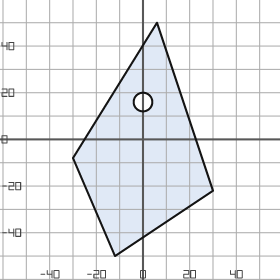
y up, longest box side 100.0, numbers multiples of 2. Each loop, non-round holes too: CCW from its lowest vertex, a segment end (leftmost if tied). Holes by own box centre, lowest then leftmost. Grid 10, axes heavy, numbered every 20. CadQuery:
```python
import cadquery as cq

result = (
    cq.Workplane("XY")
    .moveTo(-12.0, -50.0)
    .lineTo(30.0, -22.0)
    .lineTo(6.0, 50.0)
    .lineTo(-30.0, -8.0)
    .close()
    .moveTo(0.0, 16.0)
    .circle(4.0)
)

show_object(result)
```